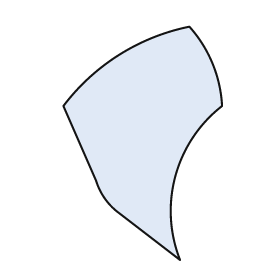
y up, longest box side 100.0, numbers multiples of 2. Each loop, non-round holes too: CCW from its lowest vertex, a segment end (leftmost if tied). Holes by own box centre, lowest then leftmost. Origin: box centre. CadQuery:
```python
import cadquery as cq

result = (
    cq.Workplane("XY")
    .moveTo(16.0, -50.0)
    .threePointArc((14.0, -14.0), (34.0, 16.0))
    .threePointArc((30.0, 34.0), (20.0, 50.0))
    .threePointArc((-10.0, 38.0), (-34.0, 16.0))
    .lineTo(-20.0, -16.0)
    .threePointArc((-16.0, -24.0), (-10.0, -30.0))
    .close()
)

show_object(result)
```